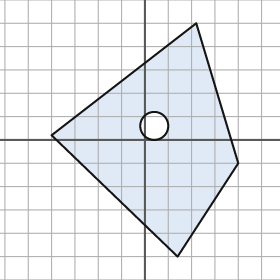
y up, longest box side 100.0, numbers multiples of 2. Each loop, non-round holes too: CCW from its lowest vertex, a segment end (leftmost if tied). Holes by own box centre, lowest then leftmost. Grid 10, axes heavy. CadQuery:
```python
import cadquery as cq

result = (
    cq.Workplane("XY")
    .moveTo(14.0, -50.0)
    .lineTo(40.0, -10.0)
    .lineTo(22.0, 50.0)
    .lineTo(-40.0, 2.0)
    .close()
    .moveTo(4.0, 6.0)
    .circle(6.0)
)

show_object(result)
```